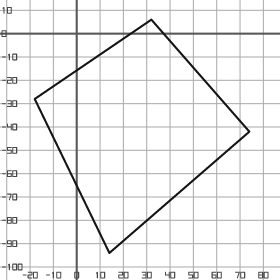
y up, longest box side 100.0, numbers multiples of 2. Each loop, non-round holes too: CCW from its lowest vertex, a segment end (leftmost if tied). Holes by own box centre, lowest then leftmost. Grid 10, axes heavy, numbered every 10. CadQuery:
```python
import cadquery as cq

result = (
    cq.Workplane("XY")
    .moveTo(14.0, -94.0)
    .lineTo(74.0, -42.0)
    .lineTo(32.0, 6.0)
    .lineTo(-18.0, -28.0)
    .close()
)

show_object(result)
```